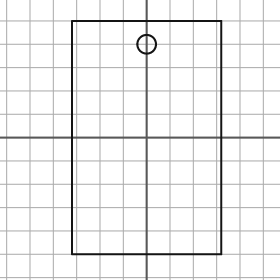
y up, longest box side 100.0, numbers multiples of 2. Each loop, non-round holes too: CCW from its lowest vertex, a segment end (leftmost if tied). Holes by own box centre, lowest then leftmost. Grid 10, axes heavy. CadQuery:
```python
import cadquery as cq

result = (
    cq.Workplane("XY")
    .moveTo(-32.0, -50.0)
    .lineTo(32.0, -50.0)
    .lineTo(32.0, 50.0)
    .lineTo(-32.0, 50.0)
    .close()
    .moveTo(0.0, 40.0)
    .circle(4.0)
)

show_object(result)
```